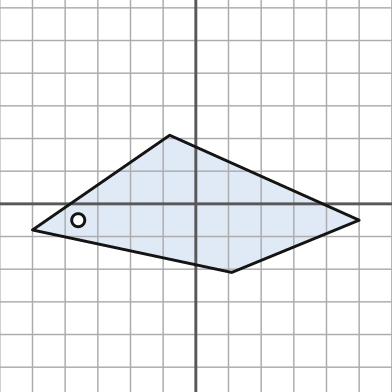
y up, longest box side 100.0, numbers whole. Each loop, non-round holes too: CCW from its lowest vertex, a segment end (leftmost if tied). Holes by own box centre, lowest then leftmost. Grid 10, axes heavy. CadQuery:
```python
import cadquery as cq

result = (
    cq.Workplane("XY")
    .moveTo(11.0, -21.0)
    .lineTo(50.0, -5.0)
    .lineTo(-8.0, 21.0)
    .lineTo(-50.0, -8.0)
    .close()
    .moveTo(-36.0, -5.0)
    .circle(2.0)
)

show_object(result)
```